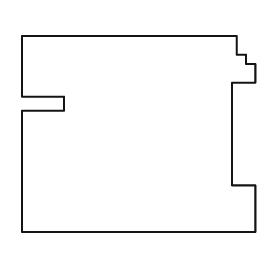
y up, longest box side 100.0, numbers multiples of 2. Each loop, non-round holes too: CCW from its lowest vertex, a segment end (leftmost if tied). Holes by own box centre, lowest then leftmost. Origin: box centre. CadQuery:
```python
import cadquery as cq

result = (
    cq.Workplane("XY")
    .moveTo(-50.0, -42.0)
    .lineTo(50.0, -42.0)
    .lineTo(50.0, -22.0)
    .lineTo(40.0, -22.0)
    .lineTo(40.0, 22.0)
    .lineTo(50.0, 22.0)
    .lineTo(50.0, 30.0)
    .lineTo(46.0, 30.0)
    .lineTo(46.0, 34.0)
    .lineTo(42.0, 34.0)
    .lineTo(42.0, 42.0)
    .lineTo(-50.0, 42.0)
    .lineTo(-50.0, 16.0)
    .lineTo(-32.0, 16.0)
    .lineTo(-32.0, 10.0)
    .lineTo(-50.0, 10.0)
    .close()
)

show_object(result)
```